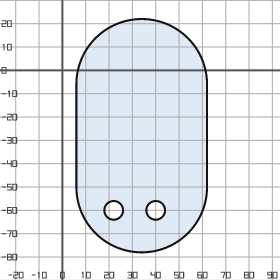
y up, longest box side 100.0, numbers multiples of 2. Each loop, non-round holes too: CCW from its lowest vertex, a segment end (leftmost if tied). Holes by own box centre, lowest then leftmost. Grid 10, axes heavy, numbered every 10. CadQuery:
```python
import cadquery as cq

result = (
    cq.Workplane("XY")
    .moveTo(6.0, -50.0)
    .threePointArc((34.0, -78.0), (62.0, -50.0))
    .lineTo(62.0, -6.0)
    .threePointArc((34.0, 22.0), (6.0, -6.0))
    .close()
    .moveTo(22.0, -60.0)
    .circle(4.0)
    .moveTo(40.0, -60.0)
    .circle(4.0)
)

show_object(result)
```